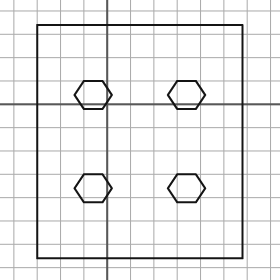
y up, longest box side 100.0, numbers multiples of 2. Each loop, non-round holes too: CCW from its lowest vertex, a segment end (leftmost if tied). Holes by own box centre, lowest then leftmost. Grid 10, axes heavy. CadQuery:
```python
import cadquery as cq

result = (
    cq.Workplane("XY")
    .moveTo(-30.0, -66.0)
    .lineTo(58.0, -66.0)
    .lineTo(58.0, 34.0)
    .lineTo(-30.0, 34.0)
    .close()
    .moveTo(-10.0, -42.0)
    .lineTo(-2.0, -42.0)
    .lineTo(2.0, -36.0)
    .lineTo(-2.0, -30.0)
    .lineTo(-10.0, -30.0)
    .lineTo(-14.0, -36.0)
    .close()
    .moveTo(30.0, -42.0)
    .lineTo(38.0, -42.0)
    .lineTo(42.0, -36.0)
    .lineTo(38.0, -30.0)
    .lineTo(30.0, -30.0)
    .lineTo(26.0, -36.0)
    .close()
    .moveTo(-10.0, -2.0)
    .lineTo(-2.0, -2.0)
    .lineTo(2.0, 4.0)
    .lineTo(-2.0, 10.0)
    .lineTo(-10.0, 10.0)
    .lineTo(-14.0, 4.0)
    .close()
    .moveTo(30.0, -2.0)
    .lineTo(38.0, -2.0)
    .lineTo(42.0, 4.0)
    .lineTo(38.0, 10.0)
    .lineTo(30.0, 10.0)
    .lineTo(26.0, 4.0)
    .close()
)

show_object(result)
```